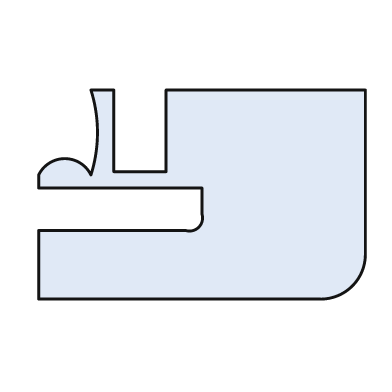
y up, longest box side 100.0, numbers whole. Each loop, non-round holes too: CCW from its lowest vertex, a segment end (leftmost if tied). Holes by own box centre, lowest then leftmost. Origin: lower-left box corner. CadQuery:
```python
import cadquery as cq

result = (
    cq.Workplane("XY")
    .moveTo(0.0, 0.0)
    .lineTo(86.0, 0.0)
    .threePointArc((96.0, 4.0), (100.0, 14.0))
    .lineTo(100.0, 64.0)
    .lineTo(39.0, 64.0)
    .lineTo(39.0, 39.0)
    .lineTo(23.0, 39.0)
    .lineTo(23.0, 64.0)
    .lineTo(16.0, 64.0)
    .threePointArc((18.0, 51.0), (16.0, 38.0))
    .threePointArc((8.0, 43.0), (0.0, 38.0))
    .lineTo(0.0, 34.0)
    .lineTo(50.0, 34.0)
    .lineTo(50.0, 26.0)
    .threePointArc((49.0, 22.0), (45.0, 21.0))
    .lineTo(0.0, 21.0)
    .close()
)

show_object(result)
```